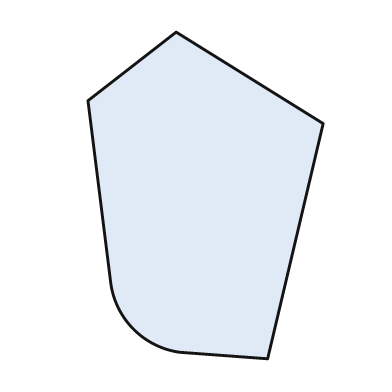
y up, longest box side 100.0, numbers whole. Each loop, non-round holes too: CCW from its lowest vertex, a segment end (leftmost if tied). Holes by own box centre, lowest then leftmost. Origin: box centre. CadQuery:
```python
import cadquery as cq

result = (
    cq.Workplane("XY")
    .moveTo(19.0, -50.0)
    .lineTo(36.0, 22.0)
    .lineTo(-9.0, 50.0)
    .lineTo(-36.0, 29.0)
    .lineTo(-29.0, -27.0)
    .threePointArc((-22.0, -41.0), (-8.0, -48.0))
    .close()
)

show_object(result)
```